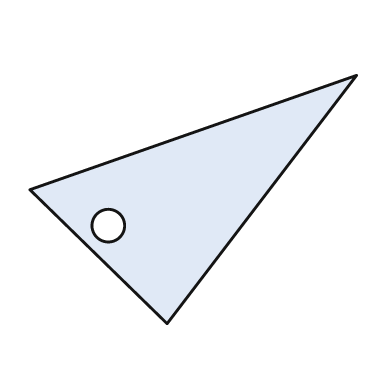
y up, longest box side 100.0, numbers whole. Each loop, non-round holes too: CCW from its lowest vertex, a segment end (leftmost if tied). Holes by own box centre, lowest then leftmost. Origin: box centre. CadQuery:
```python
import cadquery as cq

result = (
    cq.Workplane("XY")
    .moveTo(-8.0, -38.0)
    .lineTo(50.0, 38.0)
    .lineTo(-50.0, 3.0)
    .close()
    .moveTo(-26.0, -8.0)
    .circle(5.0)
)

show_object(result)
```